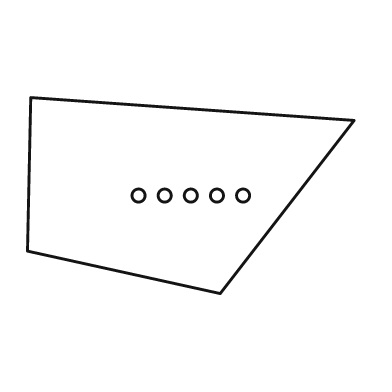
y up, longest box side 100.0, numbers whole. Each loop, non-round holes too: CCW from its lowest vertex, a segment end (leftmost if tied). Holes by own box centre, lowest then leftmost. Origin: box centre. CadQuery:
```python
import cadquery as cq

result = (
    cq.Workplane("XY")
    .moveTo(9.0, -30.0)
    .lineTo(50.0, 23.0)
    .lineTo(-49.0, 30.0)
    .lineTo(-50.0, -17.0)
    .close()
    .moveTo(-16.0, 0.0)
    .circle(2.0)
    .moveTo(-8.0, 0.0)
    .circle(2.0)
    .moveTo(0.0, 0.0)
    .circle(2.0)
    .moveTo(8.0, 0.0)
    .circle(2.0)
    .moveTo(16.0, 0.0)
    .circle(2.0)
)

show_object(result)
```